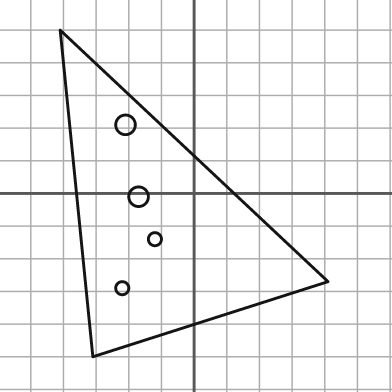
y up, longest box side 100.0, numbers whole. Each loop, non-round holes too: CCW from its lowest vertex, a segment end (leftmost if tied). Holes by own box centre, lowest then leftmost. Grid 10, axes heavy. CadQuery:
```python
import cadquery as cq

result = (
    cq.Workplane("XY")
    .moveTo(-31.0, -50.0)
    .lineTo(41.0, -27.0)
    .lineTo(-41.0, 50.0)
    .close()
    .moveTo(-22.0, -29.0)
    .circle(2.0)
    .moveTo(-12.0, -14.0)
    .circle(2.0)
    .moveTo(-17.0, -1.0)
    .circle(3.0)
    .moveTo(-21.0, 21.0)
    .circle(3.0)
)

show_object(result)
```